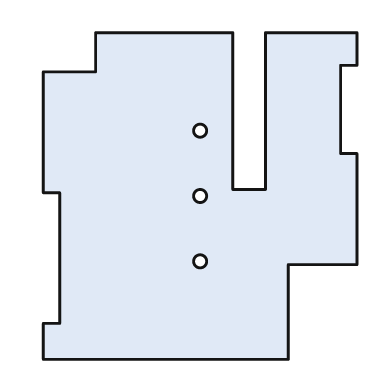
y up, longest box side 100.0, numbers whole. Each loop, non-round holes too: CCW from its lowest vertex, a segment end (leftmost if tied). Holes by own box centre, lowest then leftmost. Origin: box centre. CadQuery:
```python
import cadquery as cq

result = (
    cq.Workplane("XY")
    .moveTo(-48.0, -50.0)
    .lineTo(27.0, -50.0)
    .lineTo(27.0, -21.0)
    .lineTo(48.0, -21.0)
    .lineTo(48.0, 13.0)
    .lineTo(43.0, 13.0)
    .lineTo(43.0, 40.0)
    .lineTo(48.0, 40.0)
    .lineTo(48.0, 50.0)
    .lineTo(20.0, 50.0)
    .lineTo(20.0, 2.0)
    .lineTo(10.0, 2.0)
    .lineTo(10.0, 50.0)
    .lineTo(-32.0, 50.0)
    .lineTo(-32.0, 38.0)
    .lineTo(-48.0, 38.0)
    .lineTo(-48.0, 1.0)
    .lineTo(-43.0, 1.0)
    .lineTo(-43.0, -39.0)
    .lineTo(-48.0, -39.0)
    .close()
    .moveTo(0.0, -20.0)
    .circle(2.0)
    .moveTo(0.0, 0.0)
    .circle(2.0)
    .moveTo(0.0, 20.0)
    .circle(2.0)
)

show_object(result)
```